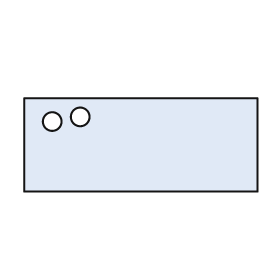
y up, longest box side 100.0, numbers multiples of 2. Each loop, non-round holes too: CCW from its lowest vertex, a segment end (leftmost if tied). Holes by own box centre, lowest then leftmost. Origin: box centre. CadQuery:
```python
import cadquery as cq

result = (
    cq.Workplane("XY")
    .moveTo(-50.0, -20.0)
    .lineTo(50.0, -20.0)
    .lineTo(50.0, 20.0)
    .lineTo(-50.0, 20.0)
    .close()
    .moveTo(-38.0, 10.0)
    .circle(4.0)
    .moveTo(-26.0, 12.0)
    .circle(4.0)
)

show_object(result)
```